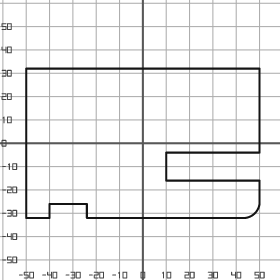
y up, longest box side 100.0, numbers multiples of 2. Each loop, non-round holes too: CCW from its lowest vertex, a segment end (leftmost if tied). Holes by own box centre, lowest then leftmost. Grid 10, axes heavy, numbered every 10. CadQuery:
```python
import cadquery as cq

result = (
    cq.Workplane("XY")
    .moveTo(-50.0, -32.0)
    .lineTo(-40.0, -32.0)
    .lineTo(-40.0, -26.0)
    .lineTo(-24.0, -26.0)
    .lineTo(-24.0, -32.0)
    .lineTo(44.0, -32.0)
    .threePointArc((48.0, -30.0), (50.0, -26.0))
    .lineTo(50.0, -16.0)
    .lineTo(10.0, -16.0)
    .lineTo(10.0, -4.0)
    .lineTo(50.0, -4.0)
    .lineTo(50.0, 32.0)
    .lineTo(-50.0, 32.0)
    .close()
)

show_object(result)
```